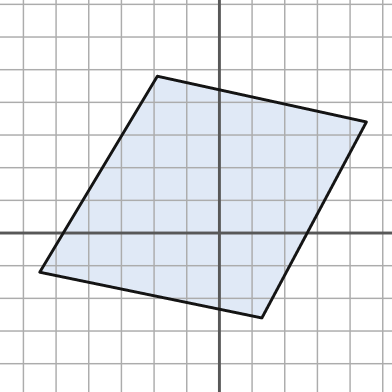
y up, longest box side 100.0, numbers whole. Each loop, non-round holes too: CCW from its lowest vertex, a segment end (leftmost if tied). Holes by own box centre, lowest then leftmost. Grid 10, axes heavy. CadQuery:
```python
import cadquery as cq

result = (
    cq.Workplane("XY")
    .moveTo(13.0, -26.0)
    .lineTo(45.0, 34.0)
    .lineTo(-19.0, 48.0)
    .lineTo(-55.0, -12.0)
    .close()
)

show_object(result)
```